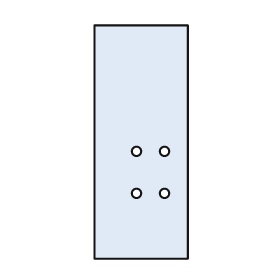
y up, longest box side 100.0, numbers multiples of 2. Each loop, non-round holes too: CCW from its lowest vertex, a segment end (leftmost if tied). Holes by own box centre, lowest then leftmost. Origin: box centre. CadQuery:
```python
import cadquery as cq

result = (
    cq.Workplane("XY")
    .moveTo(-20.0, -50.0)
    .lineTo(20.0, -50.0)
    .lineTo(20.0, 50.0)
    .lineTo(-20.0, 50.0)
    .close()
    .moveTo(-2.0, -22.0)
    .circle(2.0)
    .moveTo(10.0, -22.0)
    .circle(2.0)
    .moveTo(-2.0, -4.0)
    .circle(2.0)
    .moveTo(10.0, -4.0)
    .circle(2.0)
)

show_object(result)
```